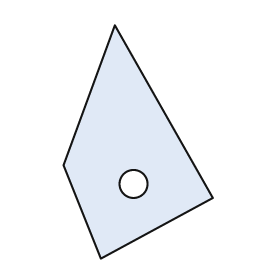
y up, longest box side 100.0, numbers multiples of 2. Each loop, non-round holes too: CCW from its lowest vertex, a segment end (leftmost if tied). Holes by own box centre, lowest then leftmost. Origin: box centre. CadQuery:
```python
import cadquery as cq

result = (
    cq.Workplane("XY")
    .moveTo(-16.0, -50.0)
    .lineTo(32.0, -24.0)
    .lineTo(-10.0, 50.0)
    .lineTo(-32.0, -10.0)
    .close()
    .moveTo(-2.0, -18.0)
    .circle(6.0)
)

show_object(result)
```